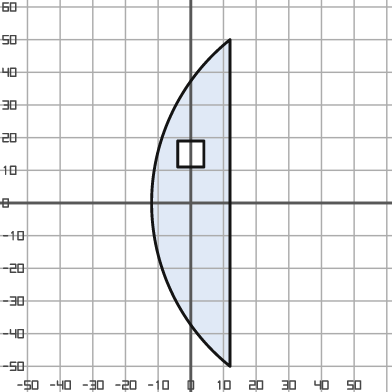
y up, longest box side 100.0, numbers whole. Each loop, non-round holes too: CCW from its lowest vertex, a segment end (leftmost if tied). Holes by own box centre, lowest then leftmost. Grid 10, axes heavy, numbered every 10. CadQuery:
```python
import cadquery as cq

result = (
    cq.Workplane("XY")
    .moveTo(12.0, -50.0)
    .lineTo(12.0, 50.0)
    .threePointArc((-12.0, 0.0), (12.0, -50.0))
    .close()
    .moveTo(-4.0, 11.0)
    .lineTo(4.0, 11.0)
    .lineTo(4.0, 19.0)
    .lineTo(-4.0, 19.0)
    .close()
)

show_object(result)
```